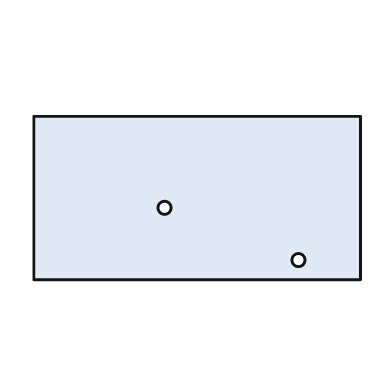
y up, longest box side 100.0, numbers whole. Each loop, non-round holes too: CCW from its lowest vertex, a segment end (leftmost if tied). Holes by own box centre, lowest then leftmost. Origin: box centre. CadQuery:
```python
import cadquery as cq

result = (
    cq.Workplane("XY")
    .moveTo(-50.0, -25.0)
    .lineTo(50.0, -25.0)
    .lineTo(50.0, 25.0)
    .lineTo(-50.0, 25.0)
    .close()
    .moveTo(31.0, -19.0)
    .circle(2.0)
    .moveTo(-10.0, -3.0)
    .circle(2.0)
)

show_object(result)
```